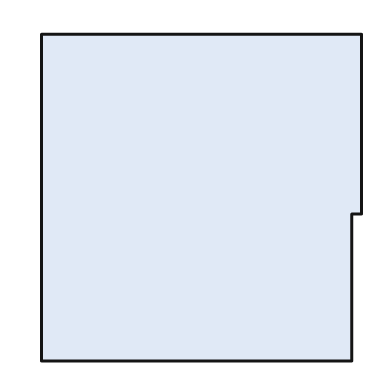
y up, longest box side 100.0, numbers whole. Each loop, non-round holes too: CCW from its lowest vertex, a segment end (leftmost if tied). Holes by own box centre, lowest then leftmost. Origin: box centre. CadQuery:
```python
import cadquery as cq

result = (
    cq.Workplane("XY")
    .moveTo(-49.0, -50.0)
    .lineTo(46.0, -50.0)
    .lineTo(46.0, -5.0)
    .lineTo(49.0, -5.0)
    .lineTo(49.0, 50.0)
    .lineTo(-49.0, 50.0)
    .close()
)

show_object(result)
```